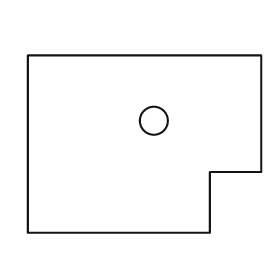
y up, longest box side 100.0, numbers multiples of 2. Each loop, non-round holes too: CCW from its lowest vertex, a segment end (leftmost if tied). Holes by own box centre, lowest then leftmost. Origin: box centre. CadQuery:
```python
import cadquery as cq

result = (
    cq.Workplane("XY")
    .moveTo(-50.0, -38.0)
    .lineTo(28.0, -38.0)
    .lineTo(28.0, -12.0)
    .lineTo(50.0, -12.0)
    .lineTo(50.0, 38.0)
    .lineTo(-50.0, 38.0)
    .close()
    .moveTo(4.0, 10.0)
    .circle(6.0)
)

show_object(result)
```